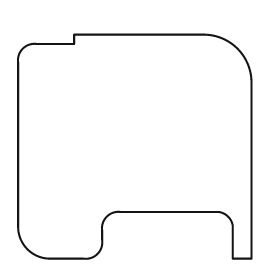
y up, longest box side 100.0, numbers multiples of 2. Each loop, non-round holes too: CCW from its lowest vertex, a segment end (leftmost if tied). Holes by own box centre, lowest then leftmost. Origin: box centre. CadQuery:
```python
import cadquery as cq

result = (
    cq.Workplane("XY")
    .moveTo(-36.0, -48.0)
    .lineTo(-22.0, -48.0)
    .threePointArc((-16.0, -46.0), (-14.0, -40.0))
    .lineTo(-14.0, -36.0)
    .threePointArc((-12.0, -30.0), (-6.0, -28.0))
    .lineTo(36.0, -28.0)
    .threePointArc((40.0, -30.0), (42.0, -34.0))
    .lineTo(42.0, -48.0)
    .lineTo(50.0, -48.0)
    .lineTo(50.0, 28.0)
    .threePointArc((44.0, 42.0), (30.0, 48.0))
    .lineTo(-26.0, 48.0)
    .lineTo(-26.0, 44.0)
    .lineTo(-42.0, 44.0)
    .threePointArc((-48.0, 42.0), (-50.0, 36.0))
    .lineTo(-50.0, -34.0)
    .threePointArc((-46.0, -44.0), (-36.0, -48.0))
    .close()
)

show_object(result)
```